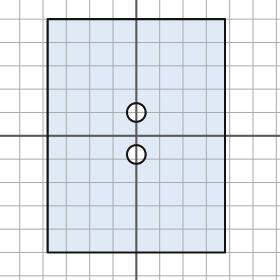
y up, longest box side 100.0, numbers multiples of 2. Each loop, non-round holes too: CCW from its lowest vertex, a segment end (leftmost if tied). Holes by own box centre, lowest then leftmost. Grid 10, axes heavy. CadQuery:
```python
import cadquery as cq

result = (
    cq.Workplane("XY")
    .moveTo(-38.0, -50.0)
    .lineTo(38.0, -50.0)
    .lineTo(38.0, 50.0)
    .lineTo(-38.0, 50.0)
    .close()
    .moveTo(0.0, -8.0)
    .circle(4.0)
    .moveTo(0.0, 10.0)
    .circle(4.0)
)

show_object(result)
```